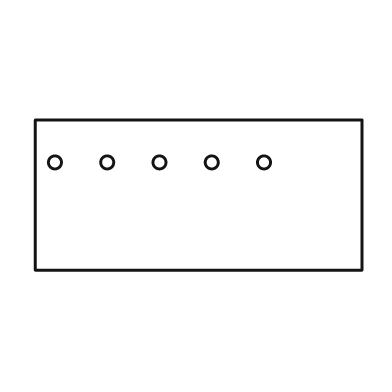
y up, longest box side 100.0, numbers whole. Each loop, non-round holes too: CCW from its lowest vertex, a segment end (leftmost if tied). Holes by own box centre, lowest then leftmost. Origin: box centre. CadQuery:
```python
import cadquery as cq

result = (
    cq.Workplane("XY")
    .moveTo(-50.0, -23.0)
    .lineTo(50.0, -23.0)
    .lineTo(50.0, 23.0)
    .lineTo(-50.0, 23.0)
    .close()
    .moveTo(-44.0, 10.0)
    .circle(2.0)
    .moveTo(-28.0, 10.0)
    .circle(2.0)
    .moveTo(-12.0, 10.0)
    .circle(2.0)
    .moveTo(4.0, 10.0)
    .circle(2.0)
    .moveTo(20.0, 10.0)
    .circle(2.0)
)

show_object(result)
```